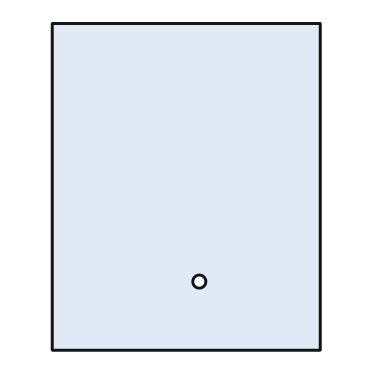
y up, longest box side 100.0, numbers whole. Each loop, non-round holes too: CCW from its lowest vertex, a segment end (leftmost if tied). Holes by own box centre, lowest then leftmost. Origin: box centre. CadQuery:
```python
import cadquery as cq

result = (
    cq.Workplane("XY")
    .moveTo(-41.0, -50.0)
    .lineTo(41.0, -50.0)
    .lineTo(41.0, 50.0)
    .lineTo(-41.0, 50.0)
    .close()
    .moveTo(4.0, -29.0)
    .circle(2.0)
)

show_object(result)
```